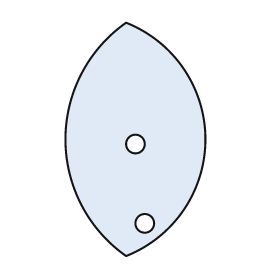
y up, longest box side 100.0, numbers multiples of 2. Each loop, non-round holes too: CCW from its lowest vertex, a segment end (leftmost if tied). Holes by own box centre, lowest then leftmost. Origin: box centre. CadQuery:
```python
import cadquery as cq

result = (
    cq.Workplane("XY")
    .moveTo(-4.0, -50.0)
    .threePointArc((30.0, 0.0), (-4.0, 50.0))
    .threePointArc((-30.0, 0.0), (-4.0, -50.0))
    .close()
    .moveTo(4.0, -36.0)
    .circle(4.0)
    .moveTo(0.0, -2.0)
    .circle(4.0)
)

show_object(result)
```